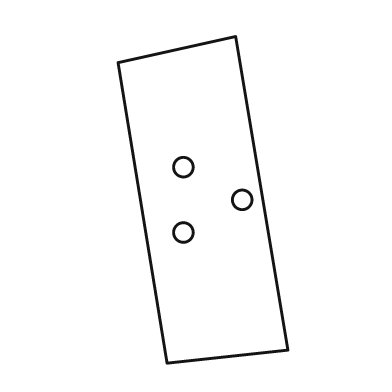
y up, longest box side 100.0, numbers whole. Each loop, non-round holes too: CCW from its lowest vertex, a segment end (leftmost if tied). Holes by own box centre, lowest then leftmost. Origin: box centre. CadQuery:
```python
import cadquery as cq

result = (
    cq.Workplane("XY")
    .moveTo(-11.0, -50.0)
    .lineTo(26.0, -46.0)
    .lineTo(10.0, 50.0)
    .lineTo(-26.0, 42.0)
    .close()
    .moveTo(-6.0, -10.0)
    .circle(3.0)
    .moveTo(12.0, 0.0)
    .circle(3.0)
    .moveTo(-6.0, 10.0)
    .circle(3.0)
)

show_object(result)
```